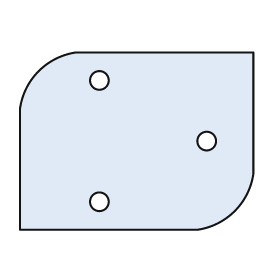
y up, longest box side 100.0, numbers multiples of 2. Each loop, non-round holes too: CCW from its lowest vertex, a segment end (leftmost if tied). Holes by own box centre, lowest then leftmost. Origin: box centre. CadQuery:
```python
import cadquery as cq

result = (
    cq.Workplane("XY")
    .moveTo(-50.0, -38.0)
    .lineTo(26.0, -38.0)
    .threePointArc((42.0, -30.0), (50.0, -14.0))
    .lineTo(50.0, 38.0)
    .lineTo(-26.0, 38.0)
    .threePointArc((-42.0, 30.0), (-50.0, 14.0))
    .close()
    .moveTo(-16.0, -26.0)
    .circle(4.0)
    .moveTo(30.0, 0.0)
    .circle(4.0)
    .moveTo(-16.0, 26.0)
    .circle(4.0)
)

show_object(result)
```